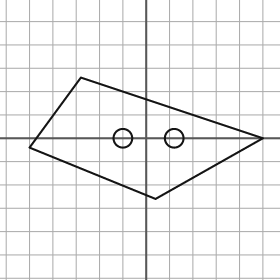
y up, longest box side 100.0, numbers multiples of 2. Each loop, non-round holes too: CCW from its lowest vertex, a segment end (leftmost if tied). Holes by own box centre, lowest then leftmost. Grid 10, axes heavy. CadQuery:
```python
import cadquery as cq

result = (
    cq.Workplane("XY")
    .moveTo(4.0, -26.0)
    .lineTo(50.0, 0.0)
    .lineTo(-28.0, 26.0)
    .lineTo(-50.0, -4.0)
    .close()
    .moveTo(-10.0, 0.0)
    .circle(4.0)
    .moveTo(12.0, 0.0)
    .circle(4.0)
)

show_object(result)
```